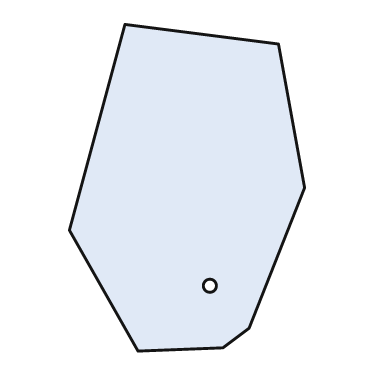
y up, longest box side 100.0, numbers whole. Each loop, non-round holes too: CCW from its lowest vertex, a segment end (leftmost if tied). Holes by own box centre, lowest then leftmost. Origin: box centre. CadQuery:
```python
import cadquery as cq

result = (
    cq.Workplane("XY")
    .moveTo(-15.0, -50.0)
    .lineTo(11.0, -49.0)
    .lineTo(19.0, -43.0)
    .lineTo(36.0, 0.0)
    .lineTo(28.0, 44.0)
    .lineTo(-19.0, 50.0)
    .lineTo(-36.0, -13.0)
    .close()
    .moveTo(7.0, -30.0)
    .circle(2.0)
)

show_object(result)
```